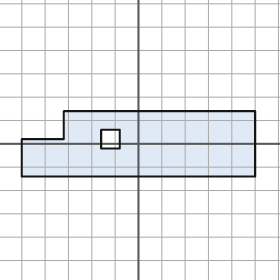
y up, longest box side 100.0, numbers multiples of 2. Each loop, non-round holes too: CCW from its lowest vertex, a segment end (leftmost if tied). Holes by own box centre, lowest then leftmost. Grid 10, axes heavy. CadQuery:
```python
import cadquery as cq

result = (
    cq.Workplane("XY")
    .moveTo(-50.0, -14.0)
    .lineTo(50.0, -14.0)
    .lineTo(50.0, 14.0)
    .lineTo(-32.0, 14.0)
    .lineTo(-32.0, 2.0)
    .lineTo(-50.0, 2.0)
    .close()
    .moveTo(-16.0, -2.0)
    .lineTo(-8.0, -2.0)
    .lineTo(-8.0, 6.0)
    .lineTo(-16.0, 6.0)
    .close()
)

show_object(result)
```